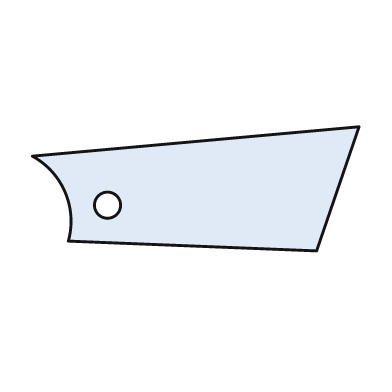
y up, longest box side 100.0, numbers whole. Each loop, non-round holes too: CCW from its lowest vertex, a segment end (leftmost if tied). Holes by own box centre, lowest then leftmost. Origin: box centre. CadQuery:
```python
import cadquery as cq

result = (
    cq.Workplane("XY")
    .moveTo(37.0, -19.0)
    .lineTo(50.0, 19.0)
    .lineTo(-50.0, 10.0)
    .threePointArc((-40.0, -1.0), (-39.0, -16.0))
    .close()
    .moveTo(-27.0, -5.0)
    .circle(4.0)
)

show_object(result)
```